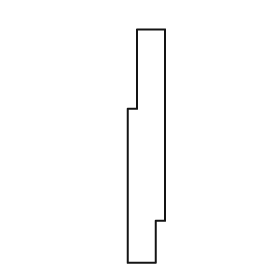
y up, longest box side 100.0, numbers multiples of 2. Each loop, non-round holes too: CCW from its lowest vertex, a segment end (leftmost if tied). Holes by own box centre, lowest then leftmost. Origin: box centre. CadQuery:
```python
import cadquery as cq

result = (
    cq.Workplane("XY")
    .moveTo(-8.0, -50.0)
    .lineTo(4.0, -50.0)
    .lineTo(4.0, -32.0)
    .lineTo(8.0, -32.0)
    .lineTo(8.0, 50.0)
    .lineTo(-4.0, 50.0)
    .lineTo(-4.0, 16.0)
    .lineTo(-8.0, 16.0)
    .close()
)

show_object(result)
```